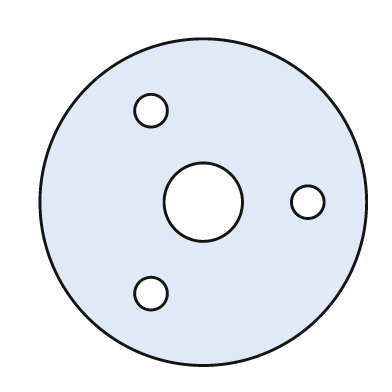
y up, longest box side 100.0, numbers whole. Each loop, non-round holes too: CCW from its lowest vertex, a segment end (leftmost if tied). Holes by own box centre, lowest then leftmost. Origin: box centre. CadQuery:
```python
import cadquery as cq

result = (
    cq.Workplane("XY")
    .moveTo(0.0, 0.0)
    .circle(50.0)
    .moveTo(-16.0, -28.0)
    .circle(5.0)
    .moveTo(0.0, 0.0)
    .circle(12.0)
    .moveTo(32.0, 0.0)
    .circle(5.0)
    .moveTo(-16.0, 28.0)
    .circle(5.0)
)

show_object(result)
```